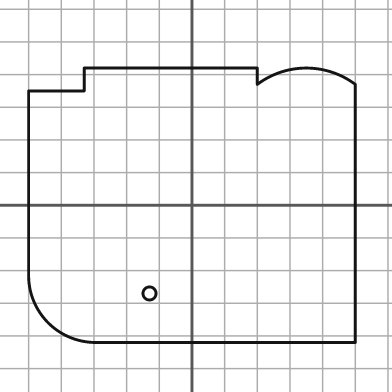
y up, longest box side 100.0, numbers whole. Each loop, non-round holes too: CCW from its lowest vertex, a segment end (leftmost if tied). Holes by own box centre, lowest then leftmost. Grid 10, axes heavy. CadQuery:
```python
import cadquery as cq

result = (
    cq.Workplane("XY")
    .moveTo(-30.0, -42.0)
    .lineTo(50.0, -42.0)
    .lineTo(50.0, 37.0)
    .threePointArc((35.0, 42.0), (20.0, 37.0))
    .lineTo(20.0, 42.0)
    .lineTo(-33.0, 42.0)
    .lineTo(-33.0, 35.0)
    .lineTo(-50.0, 35.0)
    .lineTo(-50.0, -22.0)
    .threePointArc((-44.0, -36.0), (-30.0, -42.0))
    .close()
    .moveTo(-13.0, -27.0)
    .circle(2.0)
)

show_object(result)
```